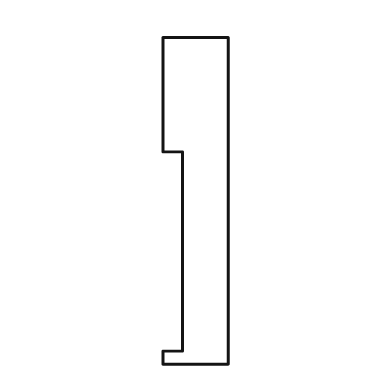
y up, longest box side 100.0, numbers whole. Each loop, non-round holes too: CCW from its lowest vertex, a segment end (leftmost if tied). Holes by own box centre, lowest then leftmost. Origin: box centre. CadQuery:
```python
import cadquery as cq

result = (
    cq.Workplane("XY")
    .moveTo(-10.0, -50.0)
    .lineTo(10.0, -50.0)
    .lineTo(10.0, 50.0)
    .lineTo(-10.0, 50.0)
    .lineTo(-10.0, 15.0)
    .lineTo(-4.0, 15.0)
    .lineTo(-4.0, -46.0)
    .lineTo(-10.0, -46.0)
    .close()
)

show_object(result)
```